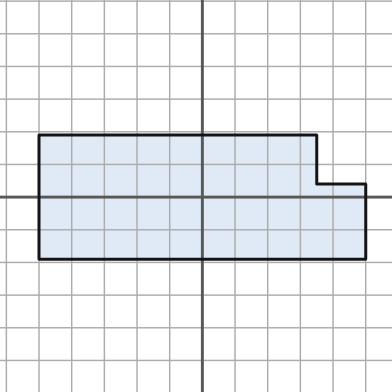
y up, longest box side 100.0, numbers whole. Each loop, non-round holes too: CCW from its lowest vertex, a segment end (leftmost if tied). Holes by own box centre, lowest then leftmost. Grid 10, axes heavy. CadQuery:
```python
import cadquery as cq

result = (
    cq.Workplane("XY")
    .moveTo(-50.0, -19.0)
    .lineTo(50.0, -19.0)
    .lineTo(50.0, 4.0)
    .lineTo(35.0, 4.0)
    .lineTo(35.0, 19.0)
    .lineTo(-50.0, 19.0)
    .close()
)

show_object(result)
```